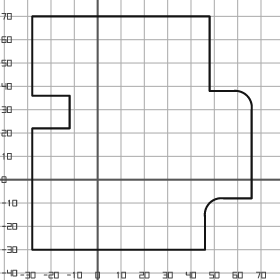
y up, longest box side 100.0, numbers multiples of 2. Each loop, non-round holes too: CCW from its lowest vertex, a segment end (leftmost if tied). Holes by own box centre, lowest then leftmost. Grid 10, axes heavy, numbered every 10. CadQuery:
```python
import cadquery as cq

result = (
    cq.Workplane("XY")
    .moveTo(-28.0, -30.0)
    .lineTo(46.0, -30.0)
    .lineTo(46.0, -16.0)
    .threePointArc((48.0, -10.0), (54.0, -8.0))
    .lineTo(66.0, -8.0)
    .lineTo(66.0, 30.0)
    .threePointArc((64.0, 36.0), (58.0, 38.0))
    .lineTo(48.0, 38.0)
    .lineTo(48.0, 70.0)
    .lineTo(-28.0, 70.0)
    .lineTo(-28.0, 36.0)
    .lineTo(-12.0, 36.0)
    .lineTo(-12.0, 22.0)
    .lineTo(-28.0, 22.0)
    .close()
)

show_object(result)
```